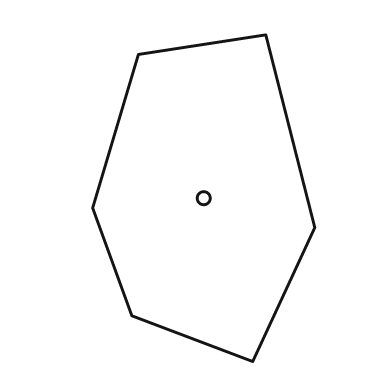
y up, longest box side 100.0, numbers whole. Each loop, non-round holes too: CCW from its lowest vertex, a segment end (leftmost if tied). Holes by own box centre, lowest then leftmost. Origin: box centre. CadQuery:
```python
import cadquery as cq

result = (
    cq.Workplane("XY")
    .moveTo(15.0, -50.0)
    .lineTo(34.0, -9.0)
    .lineTo(19.0, 50.0)
    .lineTo(-20.0, 44.0)
    .lineTo(-34.0, -3.0)
    .lineTo(-22.0, -36.0)
    .close()
    .moveTo(0.0, 0.0)
    .circle(2.0)
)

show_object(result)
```